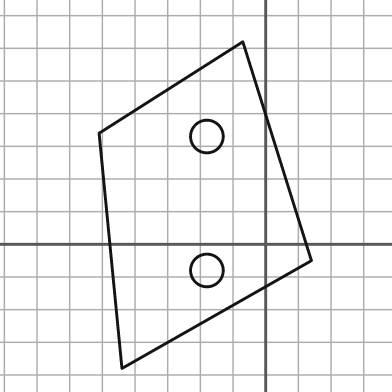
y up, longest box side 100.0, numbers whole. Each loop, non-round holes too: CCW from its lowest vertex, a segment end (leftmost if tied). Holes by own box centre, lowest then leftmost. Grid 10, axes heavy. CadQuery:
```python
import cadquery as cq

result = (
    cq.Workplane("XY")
    .moveTo(-44.0, -38.0)
    .lineTo(14.0, -5.0)
    .lineTo(-7.0, 62.0)
    .lineTo(-51.0, 34.0)
    .close()
    .moveTo(-18.0, -8.0)
    .circle(5.0)
    .moveTo(-18.0, 33.0)
    .circle(5.0)
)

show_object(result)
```